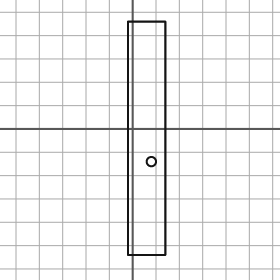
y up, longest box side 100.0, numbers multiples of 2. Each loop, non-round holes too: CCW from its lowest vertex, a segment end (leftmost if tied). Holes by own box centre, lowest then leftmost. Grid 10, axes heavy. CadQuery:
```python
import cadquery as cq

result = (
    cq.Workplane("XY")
    .moveTo(-2.0, -54.0)
    .lineTo(14.0, -54.0)
    .lineTo(14.0, 46.0)
    .lineTo(-2.0, 46.0)
    .close()
    .moveTo(8.0, -14.0)
    .circle(2.0)
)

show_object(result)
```